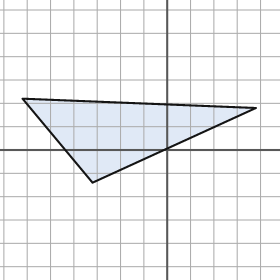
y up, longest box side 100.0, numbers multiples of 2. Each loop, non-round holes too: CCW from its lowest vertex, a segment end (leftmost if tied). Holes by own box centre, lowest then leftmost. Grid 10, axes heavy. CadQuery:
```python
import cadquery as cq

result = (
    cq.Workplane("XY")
    .moveTo(-32.0, -14.0)
    .lineTo(38.0, 18.0)
    .lineTo(-62.0, 22.0)
    .close()
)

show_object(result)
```